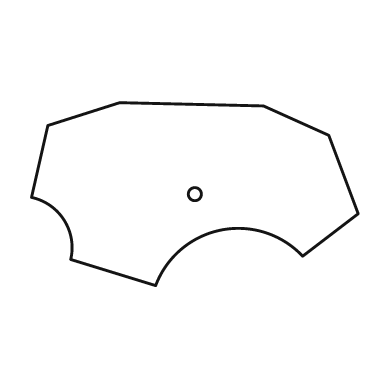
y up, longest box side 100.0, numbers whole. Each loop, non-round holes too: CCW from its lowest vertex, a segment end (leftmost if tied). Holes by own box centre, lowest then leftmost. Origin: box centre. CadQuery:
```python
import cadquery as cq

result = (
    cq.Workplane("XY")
    .moveTo(-12.0, -28.0)
    .threePointArc((8.0, -11.0), (33.0, -19.0))
    .lineTo(50.0, -6.0)
    .lineTo(41.0, 18.0)
    .lineTo(21.0, 27.0)
    .lineTo(-23.0, 28.0)
    .lineTo(-45.0, 21.0)
    .lineTo(-50.0, -1.0)
    .threePointArc((-40.0, -8.0), (-38.0, -20.0))
    .close()
    .moveTo(0.0, 0.0)
    .circle(2.0)
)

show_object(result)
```